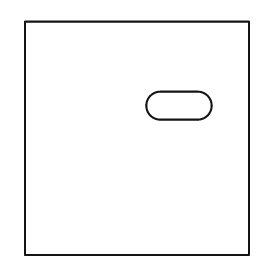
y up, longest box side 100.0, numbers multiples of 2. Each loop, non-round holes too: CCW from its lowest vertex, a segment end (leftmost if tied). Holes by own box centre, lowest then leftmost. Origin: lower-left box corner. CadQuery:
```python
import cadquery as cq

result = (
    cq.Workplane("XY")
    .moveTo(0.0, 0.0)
    .lineTo(96.0, 0.0)
    .lineTo(96.0, 100.0)
    .lineTo(0.0, 100.0)
    .close()
    .moveTo(58.0, 58.0)
    .lineTo(74.0, 58.0)
    .threePointArc((80.0, 64.0), (74.0, 70.0))
    .lineTo(58.0, 70.0)
    .threePointArc((52.0, 64.0), (58.0, 58.0))
    .close()
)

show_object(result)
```